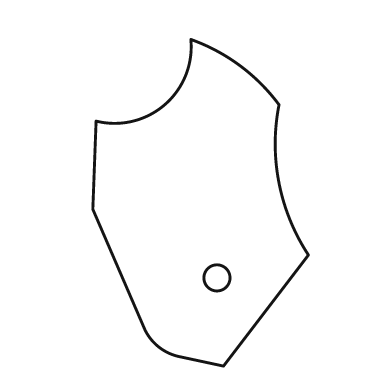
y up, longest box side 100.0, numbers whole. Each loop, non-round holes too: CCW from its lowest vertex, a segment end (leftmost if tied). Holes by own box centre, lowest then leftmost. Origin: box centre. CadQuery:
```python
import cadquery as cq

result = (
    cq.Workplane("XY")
    .moveTo(7.0, -50.0)
    .lineTo(33.0, -16.0)
    .threePointArc((24.0, 6.0), (24.0, 30.0))
    .threePointArc((12.0, 42.0), (-3.0, 50.0))
    .threePointArc((-11.0, 30.0), (-32.0, 25.0))
    .lineTo(-33.0, -2.0)
    .lineTo(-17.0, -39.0)
    .threePointArc((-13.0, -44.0), (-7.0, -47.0))
    .close()
    .moveTo(5.0, -23.0)
    .circle(4.0)
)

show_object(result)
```